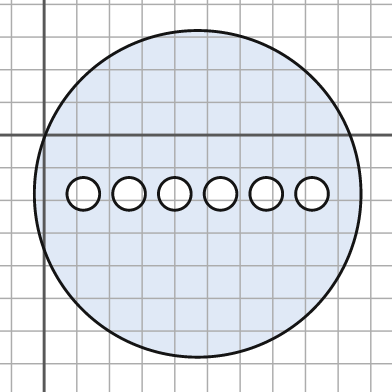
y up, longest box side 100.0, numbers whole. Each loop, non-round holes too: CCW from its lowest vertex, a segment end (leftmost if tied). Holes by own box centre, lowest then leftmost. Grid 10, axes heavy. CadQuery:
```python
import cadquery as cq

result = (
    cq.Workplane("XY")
    .moveTo(47.0, -18.0)
    .circle(50.0)
    .moveTo(12.0, -18.0)
    .circle(5.0)
    .moveTo(26.0, -18.0)
    .circle(5.0)
    .moveTo(40.0, -18.0)
    .circle(5.0)
    .moveTo(54.0, -18.0)
    .circle(5.0)
    .moveTo(68.0, -18.0)
    .circle(5.0)
    .moveTo(82.0, -18.0)
    .circle(5.0)
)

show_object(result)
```